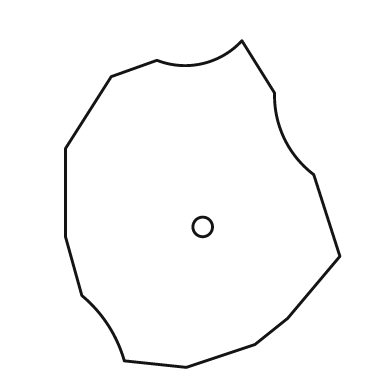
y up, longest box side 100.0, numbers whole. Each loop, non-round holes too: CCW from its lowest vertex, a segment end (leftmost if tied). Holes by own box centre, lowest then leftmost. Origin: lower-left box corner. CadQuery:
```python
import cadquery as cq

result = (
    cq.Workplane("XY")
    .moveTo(37.0, 0.0)
    .lineTo(58.0, 7.0)
    .lineTo(68.0, 15.0)
    .lineTo(84.0, 34.0)
    .lineTo(76.0, 59.0)
    .threePointArc((67.0, 70.0), (64.0, 84.0))
    .lineTo(54.0, 100.0)
    .threePointArc((42.0, 93.0), (28.0, 94.0))
    .lineTo(14.0, 89.0)
    .lineTo(0.0, 67.0)
    .lineTo(0.0, 40.0)
    .lineTo(5.0, 22.0)
    .threePointArc((13.0, 13.0), (18.0, 2.0))
    .close()
    .moveTo(42.0, 43.0)
    .circle(3.0)
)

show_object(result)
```